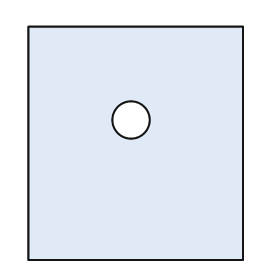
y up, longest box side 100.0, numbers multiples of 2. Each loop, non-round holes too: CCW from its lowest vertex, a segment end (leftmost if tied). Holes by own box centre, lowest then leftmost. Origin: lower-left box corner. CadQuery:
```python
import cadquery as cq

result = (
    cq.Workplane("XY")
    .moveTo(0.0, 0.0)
    .lineTo(92.0, 0.0)
    .lineTo(92.0, 100.0)
    .lineTo(0.0, 100.0)
    .close()
    .moveTo(44.0, 60.0)
    .circle(8.0)
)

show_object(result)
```